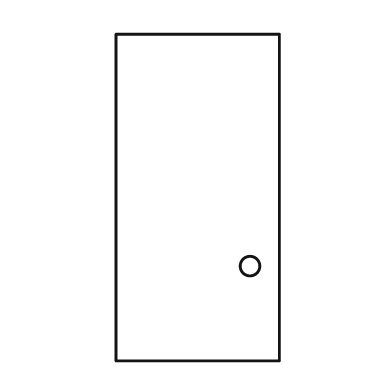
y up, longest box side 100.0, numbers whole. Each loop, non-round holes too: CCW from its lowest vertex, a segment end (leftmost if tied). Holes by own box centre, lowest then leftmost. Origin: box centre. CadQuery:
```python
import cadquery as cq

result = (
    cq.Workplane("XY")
    .moveTo(-25.0, -50.0)
    .lineTo(25.0, -50.0)
    .lineTo(25.0, 50.0)
    .lineTo(-25.0, 50.0)
    .close()
    .moveTo(16.0, -21.0)
    .circle(3.0)
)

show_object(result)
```